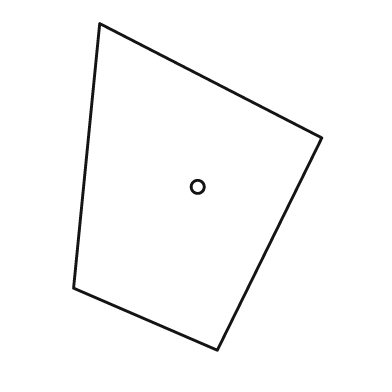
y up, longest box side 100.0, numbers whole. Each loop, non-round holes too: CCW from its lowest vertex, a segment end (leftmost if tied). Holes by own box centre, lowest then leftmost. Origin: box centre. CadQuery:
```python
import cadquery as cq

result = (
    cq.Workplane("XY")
    .moveTo(6.0, -50.0)
    .lineTo(38.0, 15.0)
    .lineTo(-30.0, 50.0)
    .lineTo(-38.0, -31.0)
    .close()
    .moveTo(0.0, 0.0)
    .circle(2.0)
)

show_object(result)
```